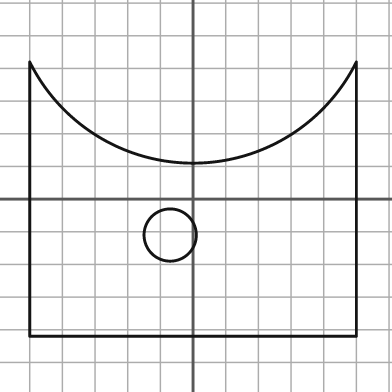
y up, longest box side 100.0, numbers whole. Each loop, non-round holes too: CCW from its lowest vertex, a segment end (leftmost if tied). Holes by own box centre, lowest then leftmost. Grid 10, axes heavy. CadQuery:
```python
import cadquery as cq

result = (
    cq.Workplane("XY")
    .moveTo(-50.0, -42.0)
    .lineTo(50.0, -42.0)
    .lineTo(50.0, 42.0)
    .threePointArc((0.0, 11.0), (-50.0, 42.0))
    .close()
    .moveTo(-7.0, -11.0)
    .circle(8.0)
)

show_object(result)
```